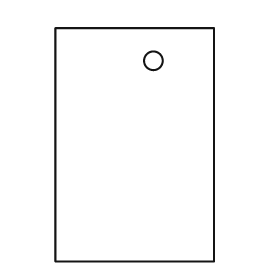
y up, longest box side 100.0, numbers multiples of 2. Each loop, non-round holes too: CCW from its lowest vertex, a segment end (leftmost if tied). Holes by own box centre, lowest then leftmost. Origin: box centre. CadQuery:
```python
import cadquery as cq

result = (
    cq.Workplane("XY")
    .moveTo(-34.0, -50.0)
    .lineTo(34.0, -50.0)
    .lineTo(34.0, 50.0)
    .lineTo(-34.0, 50.0)
    .close()
    .moveTo(8.0, 36.0)
    .circle(4.0)
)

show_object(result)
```